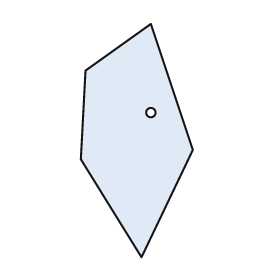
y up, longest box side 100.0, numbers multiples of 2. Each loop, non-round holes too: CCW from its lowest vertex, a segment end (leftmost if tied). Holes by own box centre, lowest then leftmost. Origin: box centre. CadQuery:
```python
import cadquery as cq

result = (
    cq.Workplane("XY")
    .moveTo(2.0, -50.0)
    .lineTo(24.0, -4.0)
    .lineTo(6.0, 50.0)
    .lineTo(-22.0, 30.0)
    .lineTo(-24.0, -8.0)
    .close()
    .moveTo(6.0, 12.0)
    .circle(2.0)
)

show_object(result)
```